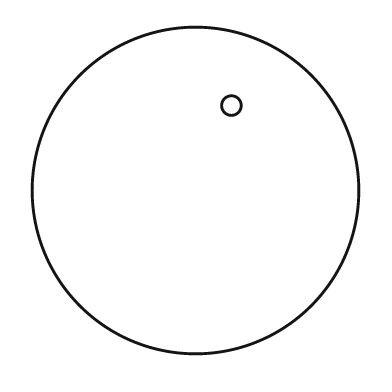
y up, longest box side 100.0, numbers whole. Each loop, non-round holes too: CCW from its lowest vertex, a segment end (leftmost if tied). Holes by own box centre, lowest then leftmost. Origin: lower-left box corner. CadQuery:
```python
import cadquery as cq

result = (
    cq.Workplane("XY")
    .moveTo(50.0, 50.0)
    .circle(50.0)
    .moveTo(61.0, 76.0)
    .circle(3.0)
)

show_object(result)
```